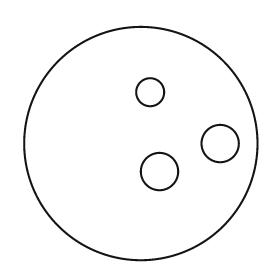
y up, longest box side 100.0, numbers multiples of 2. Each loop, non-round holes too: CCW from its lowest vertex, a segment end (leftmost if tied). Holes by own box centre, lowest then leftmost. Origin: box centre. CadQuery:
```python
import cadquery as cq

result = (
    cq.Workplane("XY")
    .moveTo(0.0, 0.0)
    .circle(50.0)
    .moveTo(8.0, -12.0)
    .circle(8.0)
    .moveTo(34.0, 0.0)
    .circle(8.0)
    .moveTo(4.0, 22.0)
    .circle(6.0)
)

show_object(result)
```